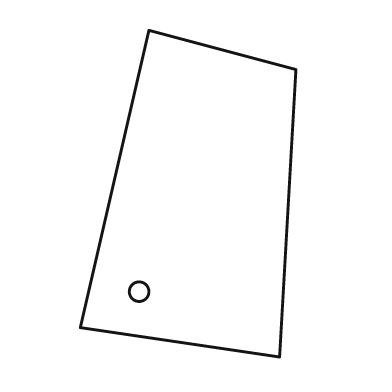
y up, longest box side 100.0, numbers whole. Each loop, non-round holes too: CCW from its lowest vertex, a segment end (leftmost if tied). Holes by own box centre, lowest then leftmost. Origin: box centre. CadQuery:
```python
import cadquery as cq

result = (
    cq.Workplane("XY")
    .moveTo(28.0, -50.0)
    .lineTo(33.0, 38.0)
    .lineTo(-12.0, 50.0)
    .lineTo(-33.0, -41.0)
    .close()
    .moveTo(-15.0, -30.0)
    .circle(3.0)
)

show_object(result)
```